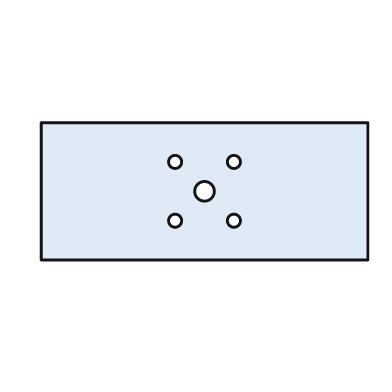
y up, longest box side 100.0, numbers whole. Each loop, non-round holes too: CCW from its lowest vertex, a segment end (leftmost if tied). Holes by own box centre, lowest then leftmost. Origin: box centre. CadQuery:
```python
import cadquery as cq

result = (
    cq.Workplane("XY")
    .moveTo(-50.0, -21.0)
    .lineTo(50.0, -21.0)
    .lineTo(50.0, 21.0)
    .lineTo(-50.0, 21.0)
    .close()
    .moveTo(-9.0, -9.0)
    .circle(2.0)
    .moveTo(9.0, -9.0)
    .circle(2.0)
    .moveTo(0.0, 0.0)
    .circle(3.0)
    .moveTo(-9.0, 9.0)
    .circle(2.0)
    .moveTo(9.0, 9.0)
    .circle(2.0)
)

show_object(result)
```